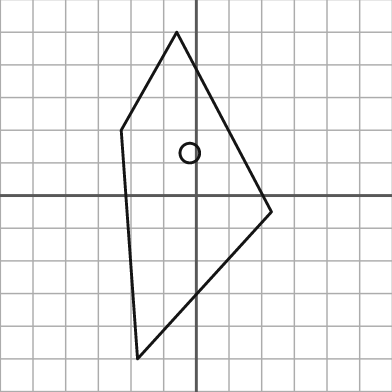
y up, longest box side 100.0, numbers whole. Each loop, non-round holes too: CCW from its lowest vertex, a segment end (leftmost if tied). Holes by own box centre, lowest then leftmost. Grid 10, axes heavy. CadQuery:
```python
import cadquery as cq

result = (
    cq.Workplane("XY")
    .moveTo(-18.0, -50.0)
    .lineTo(23.0, -5.0)
    .lineTo(-6.0, 50.0)
    .lineTo(-23.0, 20.0)
    .close()
    .moveTo(-2.0, 13.0)
    .circle(3.0)
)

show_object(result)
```